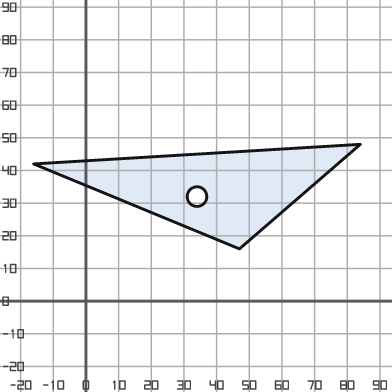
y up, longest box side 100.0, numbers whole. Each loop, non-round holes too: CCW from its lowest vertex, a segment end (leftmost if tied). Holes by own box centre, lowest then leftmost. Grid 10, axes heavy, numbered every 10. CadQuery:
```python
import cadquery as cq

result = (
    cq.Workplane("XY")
    .moveTo(47.0, 16.0)
    .lineTo(84.0, 48.0)
    .lineTo(-16.0, 42.0)
    .close()
    .moveTo(34.0, 32.0)
    .circle(3.0)
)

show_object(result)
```